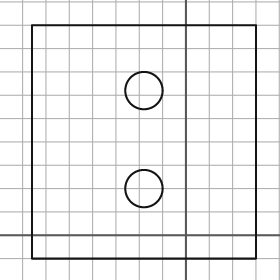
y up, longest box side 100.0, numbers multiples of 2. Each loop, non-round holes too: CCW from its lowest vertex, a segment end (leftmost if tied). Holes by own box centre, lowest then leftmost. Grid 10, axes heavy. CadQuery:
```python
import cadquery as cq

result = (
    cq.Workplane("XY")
    .moveTo(-66.0, -10.0)
    .lineTo(30.0, -10.0)
    .lineTo(30.0, 90.0)
    .lineTo(-66.0, 90.0)
    .close()
    .moveTo(-18.0, 20.0)
    .circle(8.0)
    .moveTo(-18.0, 62.0)
    .circle(8.0)
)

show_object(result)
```